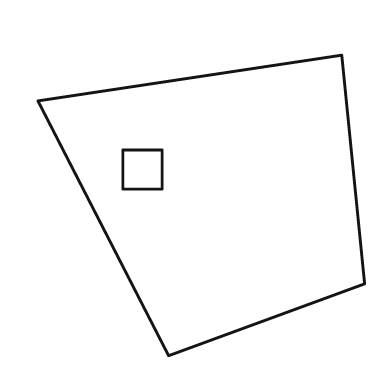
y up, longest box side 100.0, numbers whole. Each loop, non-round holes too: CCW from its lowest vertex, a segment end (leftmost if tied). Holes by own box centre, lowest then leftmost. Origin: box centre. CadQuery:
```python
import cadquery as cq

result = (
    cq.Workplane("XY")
    .moveTo(-10.0, -46.0)
    .lineTo(50.0, -24.0)
    .lineTo(43.0, 46.0)
    .lineTo(-50.0, 32.0)
    .close()
    .moveTo(-24.0, 5.0)
    .lineTo(-12.0, 5.0)
    .lineTo(-12.0, 17.0)
    .lineTo(-24.0, 17.0)
    .close()
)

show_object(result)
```